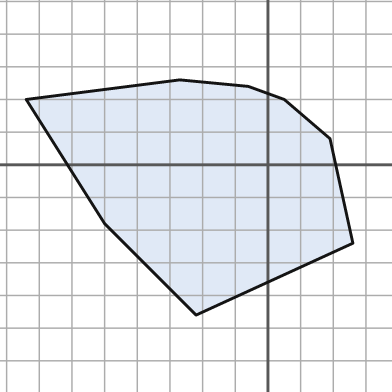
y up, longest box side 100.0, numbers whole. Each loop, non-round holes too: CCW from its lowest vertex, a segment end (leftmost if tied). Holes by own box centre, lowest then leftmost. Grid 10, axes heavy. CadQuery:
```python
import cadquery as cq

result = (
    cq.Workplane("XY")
    .moveTo(-22.0, -46.0)
    .lineTo(26.0, -24.0)
    .lineTo(19.0, 8.0)
    .lineTo(5.0, 20.0)
    .lineTo(-6.0, 24.0)
    .lineTo(-27.0, 26.0)
    .lineTo(-74.0, 20.0)
    .lineTo(-50.0, -18.0)
    .close()
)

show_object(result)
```